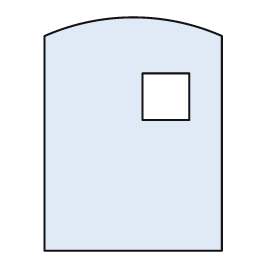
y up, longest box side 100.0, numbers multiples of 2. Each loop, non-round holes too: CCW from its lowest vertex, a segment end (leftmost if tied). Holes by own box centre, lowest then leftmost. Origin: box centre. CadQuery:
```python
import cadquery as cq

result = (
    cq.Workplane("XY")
    .moveTo(-38.0, -50.0)
    .lineTo(38.0, -50.0)
    .lineTo(38.0, 42.0)
    .threePointArc((0.0, 50.0), (-38.0, 42.0))
    .close()
    .moveTo(4.0, 6.0)
    .lineTo(24.0, 6.0)
    .lineTo(24.0, 26.0)
    .lineTo(4.0, 26.0)
    .close()
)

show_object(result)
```